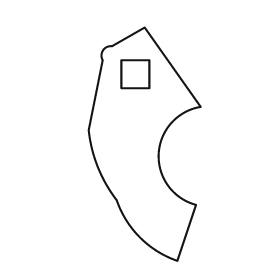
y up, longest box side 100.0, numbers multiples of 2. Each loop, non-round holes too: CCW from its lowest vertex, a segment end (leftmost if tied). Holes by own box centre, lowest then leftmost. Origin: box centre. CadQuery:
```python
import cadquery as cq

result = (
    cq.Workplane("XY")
    .moveTo(14.0, -50.0)
    .lineTo(22.0, -26.0)
    .threePointArc((6.0, -4.0), (24.0, 16.0))
    .lineTo(0.0, 50.0)
    .lineTo(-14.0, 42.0)
    .threePointArc((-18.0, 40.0), (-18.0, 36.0))
    .lineTo(-24.0, 6.0)
    .threePointArc((-20.0, -10.0), (-12.0, -24.0))
    .threePointArc((-2.0, -40.0), (14.0, -50.0))
    .close()
    .moveTo(-10.0, 24.0)
    .lineTo(2.0, 24.0)
    .lineTo(2.0, 36.0)
    .lineTo(-10.0, 36.0)
    .close()
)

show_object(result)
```